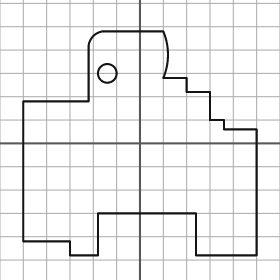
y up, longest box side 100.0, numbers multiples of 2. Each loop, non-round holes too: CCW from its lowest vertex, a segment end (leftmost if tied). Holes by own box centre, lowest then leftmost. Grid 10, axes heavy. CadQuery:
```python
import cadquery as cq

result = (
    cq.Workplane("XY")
    .moveTo(-30.0, -48.0)
    .lineTo(-18.0, -48.0)
    .lineTo(-18.0, -30.0)
    .lineTo(24.0, -30.0)
    .lineTo(24.0, -48.0)
    .lineTo(50.0, -48.0)
    .lineTo(50.0, 6.0)
    .lineTo(36.0, 6.0)
    .lineTo(36.0, 10.0)
    .lineTo(30.0, 10.0)
    .lineTo(30.0, 22.0)
    .lineTo(20.0, 22.0)
    .lineTo(20.0, 28.0)
    .lineTo(10.0, 28.0)
    .threePointArc((12.0, 38.0), (10.0, 48.0))
    .lineTo(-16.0, 48.0)
    .threePointArc((-20.0, 46.0), (-22.0, 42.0))
    .lineTo(-22.0, 18.0)
    .lineTo(-50.0, 18.0)
    .lineTo(-50.0, -42.0)
    .lineTo(-30.0, -42.0)
    .close()
    .moveTo(-14.0, 30.0)
    .circle(4.0)
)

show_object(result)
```